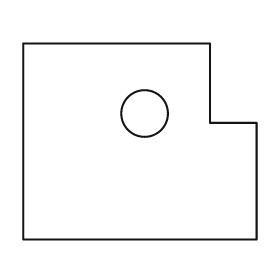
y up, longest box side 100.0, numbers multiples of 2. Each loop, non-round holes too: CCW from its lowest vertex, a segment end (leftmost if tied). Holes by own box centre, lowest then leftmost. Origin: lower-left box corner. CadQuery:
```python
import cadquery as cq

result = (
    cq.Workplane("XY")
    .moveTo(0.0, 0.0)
    .lineTo(100.0, 0.0)
    .lineTo(100.0, 50.0)
    .lineTo(80.0, 50.0)
    .lineTo(80.0, 84.0)
    .lineTo(0.0, 84.0)
    .close()
    .moveTo(52.0, 54.0)
    .circle(10.0)
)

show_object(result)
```